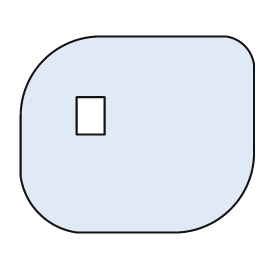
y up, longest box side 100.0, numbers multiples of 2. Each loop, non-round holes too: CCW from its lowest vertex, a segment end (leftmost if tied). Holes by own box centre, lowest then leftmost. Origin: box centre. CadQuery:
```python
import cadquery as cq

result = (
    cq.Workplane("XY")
    .moveTo(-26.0, -42.0)
    .lineTo(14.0, -42.0)
    .threePointArc((40.0, -32.0), (50.0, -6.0))
    .lineTo(50.0, 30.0)
    .threePointArc((46.0, 38.0), (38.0, 42.0))
    .lineTo(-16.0, 42.0)
    .threePointArc((-40.0, 32.0), (-50.0, 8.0))
    .lineTo(-50.0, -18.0)
    .threePointArc((-42.0, -34.0), (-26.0, -42.0))
    .close()
    .moveTo(-26.0, 0.0)
    .lineTo(-14.0, 0.0)
    .lineTo(-14.0, 16.0)
    .lineTo(-26.0, 16.0)
    .close()
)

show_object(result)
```